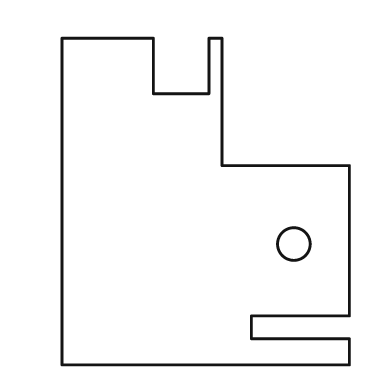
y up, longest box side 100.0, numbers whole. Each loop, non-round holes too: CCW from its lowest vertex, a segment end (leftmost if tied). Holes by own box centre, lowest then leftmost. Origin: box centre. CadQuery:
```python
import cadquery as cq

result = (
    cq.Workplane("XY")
    .moveTo(-44.0, -50.0)
    .lineTo(44.0, -50.0)
    .lineTo(44.0, -42.0)
    .lineTo(14.0, -42.0)
    .lineTo(14.0, -35.0)
    .lineTo(44.0, -35.0)
    .lineTo(44.0, 11.0)
    .lineTo(5.0, 11.0)
    .lineTo(5.0, 50.0)
    .lineTo(1.0, 50.0)
    .lineTo(1.0, 33.0)
    .lineTo(-16.0, 33.0)
    .lineTo(-16.0, 50.0)
    .lineTo(-44.0, 50.0)
    .close()
    .moveTo(27.0, -13.0)
    .circle(5.0)
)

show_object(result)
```